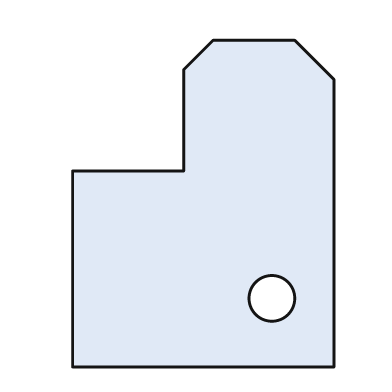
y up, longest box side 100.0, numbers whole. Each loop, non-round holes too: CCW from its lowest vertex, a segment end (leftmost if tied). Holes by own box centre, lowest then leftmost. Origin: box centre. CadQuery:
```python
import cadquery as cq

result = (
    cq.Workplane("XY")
    .moveTo(-40.0, -50.0)
    .lineTo(40.0, -50.0)
    .lineTo(40.0, 38.0)
    .lineTo(28.0, 50.0)
    .lineTo(3.0, 50.0)
    .lineTo(-6.0, 41.0)
    .lineTo(-6.0, 10.0)
    .lineTo(-40.0, 10.0)
    .close()
    .moveTo(21.0, -29.0)
    .circle(7.0)
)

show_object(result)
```